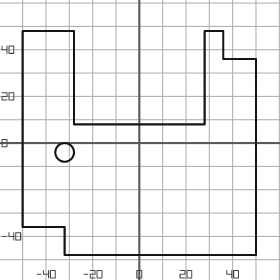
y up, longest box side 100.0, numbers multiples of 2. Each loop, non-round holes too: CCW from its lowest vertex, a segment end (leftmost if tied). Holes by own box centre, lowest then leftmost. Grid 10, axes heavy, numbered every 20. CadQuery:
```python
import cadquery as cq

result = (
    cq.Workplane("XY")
    .moveTo(-32.0, -48.0)
    .lineTo(50.0, -48.0)
    .lineTo(50.0, 36.0)
    .lineTo(36.0, 36.0)
    .lineTo(36.0, 48.0)
    .lineTo(28.0, 48.0)
    .lineTo(28.0, 8.0)
    .lineTo(-28.0, 8.0)
    .lineTo(-28.0, 48.0)
    .lineTo(-50.0, 48.0)
    .lineTo(-50.0, -36.0)
    .lineTo(-32.0, -36.0)
    .close()
    .moveTo(-32.0, -4.0)
    .circle(4.0)
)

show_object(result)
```